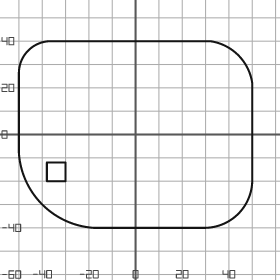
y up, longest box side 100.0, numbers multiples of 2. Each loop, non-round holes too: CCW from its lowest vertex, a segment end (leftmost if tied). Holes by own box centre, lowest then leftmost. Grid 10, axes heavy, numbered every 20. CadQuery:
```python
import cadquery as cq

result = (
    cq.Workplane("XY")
    .moveTo(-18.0, -40.0)
    .lineTo(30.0, -40.0)
    .threePointArc((44.0, -34.0), (50.0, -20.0))
    .lineTo(50.0, 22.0)
    .threePointArc((44.0, 34.0), (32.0, 40.0))
    .lineTo(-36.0, 40.0)
    .threePointArc((-46.0, 36.0), (-50.0, 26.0))
    .lineTo(-50.0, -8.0)
    .threePointArc((-40.0, -30.0), (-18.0, -40.0))
    .close()
    .moveTo(-38.0, -20.0)
    .lineTo(-30.0, -20.0)
    .lineTo(-30.0, -12.0)
    .lineTo(-38.0, -12.0)
    .close()
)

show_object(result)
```